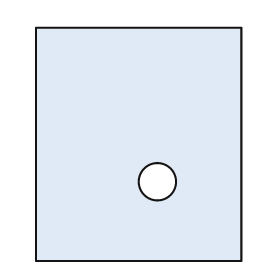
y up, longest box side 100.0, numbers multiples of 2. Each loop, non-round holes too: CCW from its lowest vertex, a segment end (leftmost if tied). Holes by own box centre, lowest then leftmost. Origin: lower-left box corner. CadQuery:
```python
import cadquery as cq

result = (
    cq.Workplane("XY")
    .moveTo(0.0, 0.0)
    .lineTo(88.0, 0.0)
    .lineTo(88.0, 100.0)
    .lineTo(0.0, 100.0)
    .close()
    .moveTo(52.0, 34.0)
    .circle(8.0)
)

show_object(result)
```